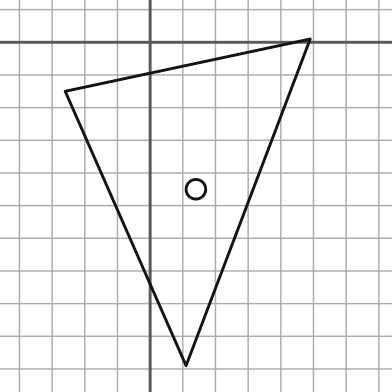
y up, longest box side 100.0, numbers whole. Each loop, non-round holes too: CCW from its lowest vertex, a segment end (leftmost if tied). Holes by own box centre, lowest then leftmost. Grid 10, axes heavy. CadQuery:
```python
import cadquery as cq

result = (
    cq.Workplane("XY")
    .moveTo(11.0, -99.0)
    .lineTo(49.0, 1.0)
    .lineTo(-26.0, -15.0)
    .close()
    .moveTo(14.0, -45.0)
    .circle(3.0)
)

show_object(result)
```